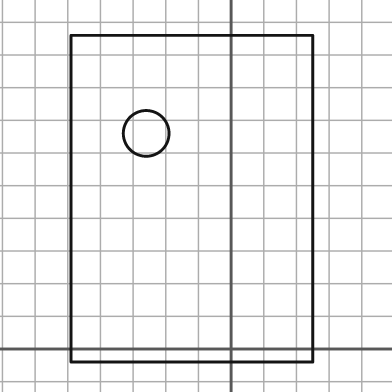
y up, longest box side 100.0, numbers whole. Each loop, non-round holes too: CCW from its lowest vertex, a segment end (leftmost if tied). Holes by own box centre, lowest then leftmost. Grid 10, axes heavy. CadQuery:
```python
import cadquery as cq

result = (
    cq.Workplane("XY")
    .moveTo(-49.0, -4.0)
    .lineTo(25.0, -4.0)
    .lineTo(25.0, 96.0)
    .lineTo(-49.0, 96.0)
    .close()
    .moveTo(-26.0, 66.0)
    .circle(7.0)
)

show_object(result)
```